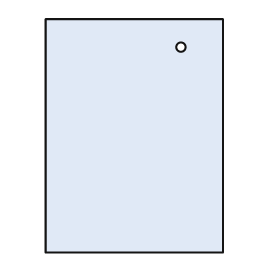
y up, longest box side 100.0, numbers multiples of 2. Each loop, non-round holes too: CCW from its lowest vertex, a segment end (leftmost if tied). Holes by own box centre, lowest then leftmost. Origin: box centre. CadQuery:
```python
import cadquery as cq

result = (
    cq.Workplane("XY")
    .moveTo(-38.0, -50.0)
    .lineTo(38.0, -50.0)
    .lineTo(38.0, 50.0)
    .lineTo(-38.0, 50.0)
    .close()
    .moveTo(20.0, 38.0)
    .circle(2.0)
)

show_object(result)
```